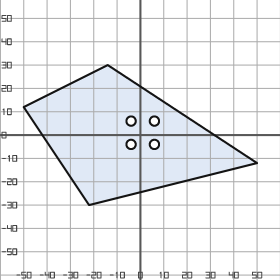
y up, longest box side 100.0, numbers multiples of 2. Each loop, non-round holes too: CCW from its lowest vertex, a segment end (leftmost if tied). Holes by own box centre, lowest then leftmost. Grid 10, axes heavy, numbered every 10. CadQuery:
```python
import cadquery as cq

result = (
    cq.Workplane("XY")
    .moveTo(-22.0, -30.0)
    .lineTo(50.0, -12.0)
    .lineTo(-14.0, 30.0)
    .lineTo(-50.0, 12.0)
    .close()
    .moveTo(-4.0, -4.0)
    .circle(2.0)
    .moveTo(6.0, -4.0)
    .circle(2.0)
    .moveTo(-4.0, 6.0)
    .circle(2.0)
    .moveTo(6.0, 6.0)
    .circle(2.0)
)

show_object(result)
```